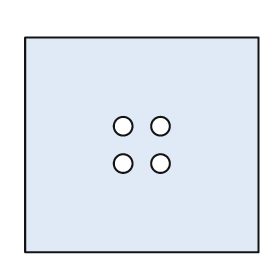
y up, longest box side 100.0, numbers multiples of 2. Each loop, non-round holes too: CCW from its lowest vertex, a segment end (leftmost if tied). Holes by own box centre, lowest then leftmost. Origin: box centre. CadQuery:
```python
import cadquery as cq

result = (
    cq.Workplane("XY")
    .moveTo(-50.0, -46.0)
    .lineTo(50.0, -46.0)
    .lineTo(50.0, 46.0)
    .lineTo(-50.0, 46.0)
    .close()
    .moveTo(-8.0, -8.0)
    .circle(4.0)
    .moveTo(8.0, -8.0)
    .circle(4.0)
    .moveTo(-8.0, 8.0)
    .circle(4.0)
    .moveTo(8.0, 8.0)
    .circle(4.0)
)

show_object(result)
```